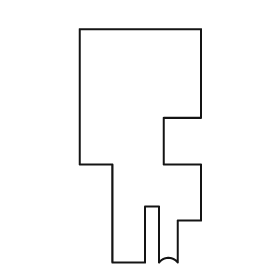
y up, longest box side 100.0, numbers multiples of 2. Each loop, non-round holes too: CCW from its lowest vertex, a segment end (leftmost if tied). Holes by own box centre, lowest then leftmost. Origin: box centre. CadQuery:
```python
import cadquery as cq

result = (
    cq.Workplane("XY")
    .moveTo(-12.0, -50.0)
    .lineTo(2.0, -50.0)
    .lineTo(2.0, -26.0)
    .lineTo(8.0, -26.0)
    .lineTo(8.0, -50.0)
    .threePointArc((12.0, -48.0), (16.0, -50.0))
    .lineTo(16.0, -32.0)
    .lineTo(26.0, -32.0)
    .lineTo(26.0, -8.0)
    .lineTo(10.0, -8.0)
    .lineTo(10.0, 12.0)
    .lineTo(26.0, 12.0)
    .lineTo(26.0, 50.0)
    .lineTo(-26.0, 50.0)
    .lineTo(-26.0, -8.0)
    .lineTo(-12.0, -8.0)
    .close()
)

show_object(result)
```